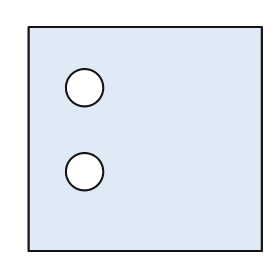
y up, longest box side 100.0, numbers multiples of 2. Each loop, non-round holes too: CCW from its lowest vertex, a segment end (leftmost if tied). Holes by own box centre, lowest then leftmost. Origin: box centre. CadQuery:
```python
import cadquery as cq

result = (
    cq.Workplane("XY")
    .moveTo(-50.0, -48.0)
    .lineTo(50.0, -48.0)
    .lineTo(50.0, 48.0)
    .lineTo(-50.0, 48.0)
    .close()
    .moveTo(-26.0, -14.0)
    .circle(8.0)
    .moveTo(-26.0, 22.0)
    .circle(8.0)
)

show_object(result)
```